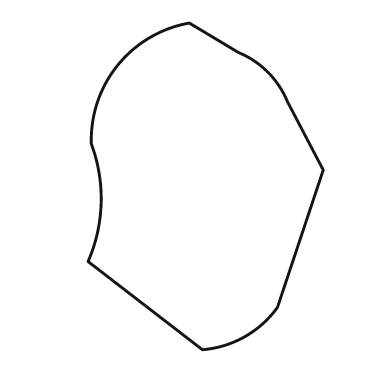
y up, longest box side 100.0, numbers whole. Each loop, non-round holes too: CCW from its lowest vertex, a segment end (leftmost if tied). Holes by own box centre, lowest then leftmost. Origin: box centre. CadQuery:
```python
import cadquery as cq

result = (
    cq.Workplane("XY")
    .moveTo(-1.0, -50.0)
    .threePointArc((12.0, -46.0), (22.0, -37.0))
    .lineTo(36.0, 5.0)
    .lineTo(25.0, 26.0)
    .threePointArc((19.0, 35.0), (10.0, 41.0))
    .lineTo(-5.0, 50.0)
    .threePointArc((-27.0, 37.0), (-35.0, 13.0))
    .threePointArc((-32.0, -5.0), (-36.0, -23.0))
    .close()
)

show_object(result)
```